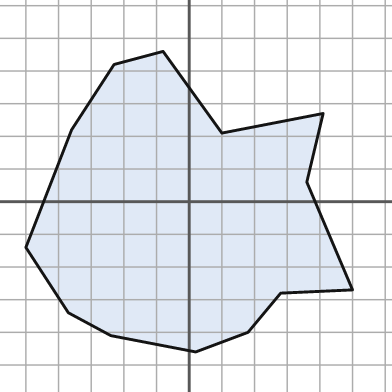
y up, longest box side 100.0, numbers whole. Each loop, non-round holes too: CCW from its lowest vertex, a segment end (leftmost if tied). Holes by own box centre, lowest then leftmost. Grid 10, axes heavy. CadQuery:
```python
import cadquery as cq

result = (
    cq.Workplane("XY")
    .moveTo(2.0, -46.0)
    .lineTo(18.0, -40.0)
    .lineTo(28.0, -28.0)
    .lineTo(50.0, -27.0)
    .lineTo(36.0, 6.0)
    .lineTo(41.0, 27.0)
    .lineTo(10.0, 21.0)
    .lineTo(-8.0, 46.0)
    .lineTo(-23.0, 42.0)
    .lineTo(-36.0, 22.0)
    .lineTo(-50.0, -14.0)
    .lineTo(-37.0, -34.0)
    .lineTo(-24.0, -41.0)
    .close()
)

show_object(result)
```